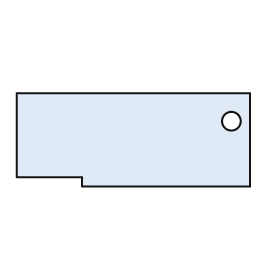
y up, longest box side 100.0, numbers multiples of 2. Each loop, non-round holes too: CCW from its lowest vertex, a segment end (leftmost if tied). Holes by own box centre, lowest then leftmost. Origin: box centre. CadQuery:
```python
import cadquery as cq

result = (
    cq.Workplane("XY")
    .moveTo(-22.0, -20.0)
    .lineTo(50.0, -20.0)
    .lineTo(50.0, 20.0)
    .lineTo(-50.0, 20.0)
    .lineTo(-50.0, -16.0)
    .lineTo(-22.0, -16.0)
    .close()
    .moveTo(42.0, 8.0)
    .circle(4.0)
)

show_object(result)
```